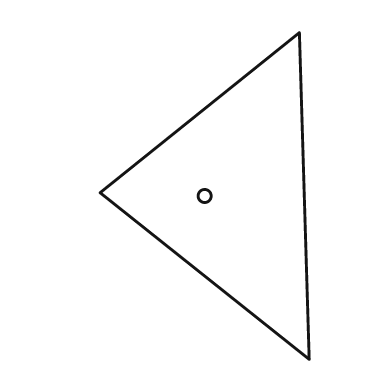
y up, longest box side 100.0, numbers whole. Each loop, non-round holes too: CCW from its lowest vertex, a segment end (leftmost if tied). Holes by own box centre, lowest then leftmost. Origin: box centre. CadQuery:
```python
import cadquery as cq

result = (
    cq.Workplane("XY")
    .moveTo(32.0, -50.0)
    .lineTo(29.0, 50.0)
    .lineTo(-32.0, 1.0)
    .close()
    .moveTo(0.0, 0.0)
    .circle(2.0)
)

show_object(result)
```